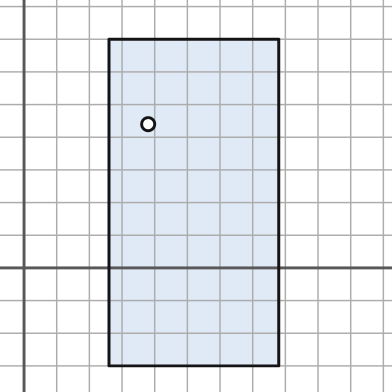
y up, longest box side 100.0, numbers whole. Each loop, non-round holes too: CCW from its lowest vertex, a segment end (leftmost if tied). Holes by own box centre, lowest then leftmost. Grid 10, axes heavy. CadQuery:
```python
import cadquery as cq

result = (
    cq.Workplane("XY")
    .moveTo(26.0, -30.0)
    .lineTo(78.0, -30.0)
    .lineTo(78.0, 70.0)
    .lineTo(26.0, 70.0)
    .close()
    .moveTo(38.0, 44.0)
    .circle(2.0)
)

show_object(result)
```